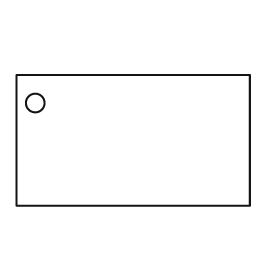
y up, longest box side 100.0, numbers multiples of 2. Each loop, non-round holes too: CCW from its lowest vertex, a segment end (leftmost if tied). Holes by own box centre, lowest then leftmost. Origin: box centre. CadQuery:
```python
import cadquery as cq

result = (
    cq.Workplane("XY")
    .moveTo(-50.0, -28.0)
    .lineTo(50.0, -28.0)
    .lineTo(50.0, 28.0)
    .lineTo(-50.0, 28.0)
    .close()
    .moveTo(-42.0, 16.0)
    .circle(4.0)
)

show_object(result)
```